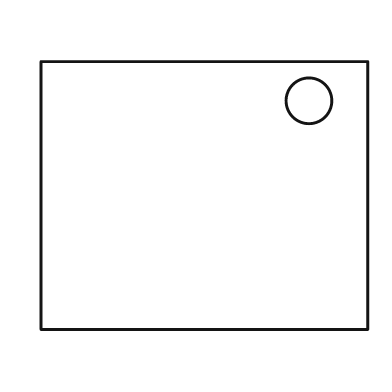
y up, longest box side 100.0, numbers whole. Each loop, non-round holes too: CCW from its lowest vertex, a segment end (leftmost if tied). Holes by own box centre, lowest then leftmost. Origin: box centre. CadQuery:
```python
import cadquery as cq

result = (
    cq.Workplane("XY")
    .moveTo(-50.0, -41.0)
    .lineTo(50.0, -41.0)
    .lineTo(50.0, 41.0)
    .lineTo(-50.0, 41.0)
    .close()
    .moveTo(32.0, 29.0)
    .circle(7.0)
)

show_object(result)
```